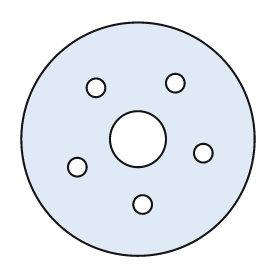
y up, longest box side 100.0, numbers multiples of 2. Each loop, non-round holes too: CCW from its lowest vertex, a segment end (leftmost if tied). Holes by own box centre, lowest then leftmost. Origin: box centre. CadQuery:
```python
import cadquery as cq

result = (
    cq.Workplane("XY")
    .moveTo(0.0, 0.0)
    .circle(50.0)
    .moveTo(2.0, -28.0)
    .circle(4.0)
    .moveTo(-26.0, -12.0)
    .circle(4.0)
    .moveTo(28.0, -6.0)
    .circle(4.0)
    .moveTo(0.0, 0.0)
    .circle(12.0)
    .moveTo(-18.0, 22.0)
    .circle(4.0)
    .moveTo(16.0, 24.0)
    .circle(4.0)
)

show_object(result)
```